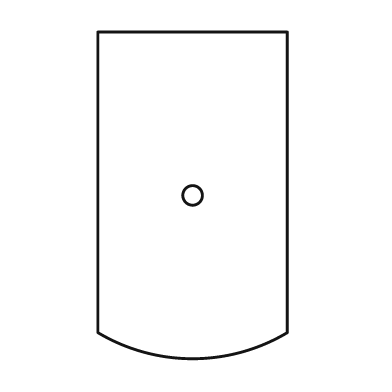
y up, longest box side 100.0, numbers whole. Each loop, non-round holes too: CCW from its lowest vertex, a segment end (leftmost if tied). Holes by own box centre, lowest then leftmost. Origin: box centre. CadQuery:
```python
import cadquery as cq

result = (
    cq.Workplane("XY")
    .moveTo(-29.0, -42.0)
    .threePointArc((0.0, -50.0), (29.0, -42.0))
    .lineTo(29.0, 50.0)
    .lineTo(-29.0, 50.0)
    .close()
    .moveTo(0.0, 0.0)
    .circle(3.0)
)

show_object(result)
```